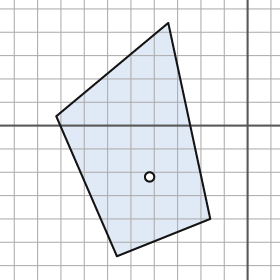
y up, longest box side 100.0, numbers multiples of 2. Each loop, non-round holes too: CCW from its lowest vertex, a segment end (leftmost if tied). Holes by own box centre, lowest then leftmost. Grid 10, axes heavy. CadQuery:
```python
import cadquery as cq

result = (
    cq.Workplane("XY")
    .moveTo(-56.0, -56.0)
    .lineTo(-16.0, -40.0)
    .lineTo(-34.0, 44.0)
    .lineTo(-82.0, 4.0)
    .close()
    .moveTo(-42.0, -22.0)
    .circle(2.0)
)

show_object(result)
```